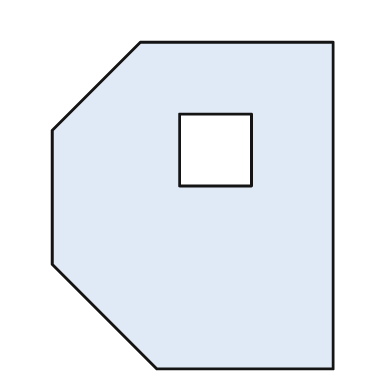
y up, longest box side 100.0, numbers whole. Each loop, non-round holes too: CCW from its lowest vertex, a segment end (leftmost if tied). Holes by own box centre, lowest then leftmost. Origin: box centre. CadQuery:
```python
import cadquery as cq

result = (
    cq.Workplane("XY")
    .moveTo(-11.0, -50.0)
    .lineTo(43.0, -50.0)
    .lineTo(43.0, 50.0)
    .lineTo(-16.0, 50.0)
    .lineTo(-43.0, 23.0)
    .lineTo(-43.0, -18.0)
    .close()
    .moveTo(-4.0, 6.0)
    .lineTo(18.0, 6.0)
    .lineTo(18.0, 28.0)
    .lineTo(-4.0, 28.0)
    .close()
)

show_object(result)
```